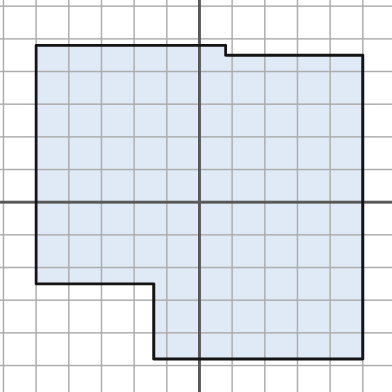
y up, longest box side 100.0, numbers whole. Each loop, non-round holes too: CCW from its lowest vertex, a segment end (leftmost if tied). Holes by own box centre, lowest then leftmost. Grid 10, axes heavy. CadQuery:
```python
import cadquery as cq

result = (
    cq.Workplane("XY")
    .moveTo(-14.0, -48.0)
    .lineTo(50.0, -48.0)
    .lineTo(50.0, 45.0)
    .lineTo(8.0, 45.0)
    .lineTo(8.0, 48.0)
    .lineTo(-50.0, 48.0)
    .lineTo(-50.0, -25.0)
    .lineTo(-14.0, -25.0)
    .close()
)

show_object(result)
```